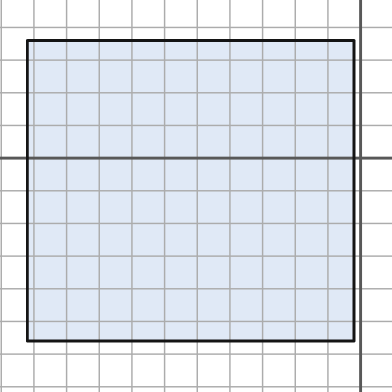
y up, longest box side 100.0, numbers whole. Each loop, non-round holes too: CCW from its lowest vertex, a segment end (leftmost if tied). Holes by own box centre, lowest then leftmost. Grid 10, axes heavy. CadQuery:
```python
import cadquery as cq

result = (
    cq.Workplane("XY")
    .moveTo(-102.0, -56.0)
    .lineTo(-2.0, -56.0)
    .lineTo(-2.0, 36.0)
    .lineTo(-102.0, 36.0)
    .close()
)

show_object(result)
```